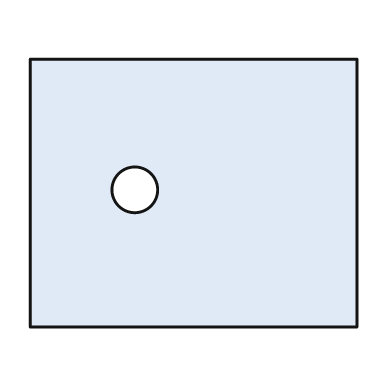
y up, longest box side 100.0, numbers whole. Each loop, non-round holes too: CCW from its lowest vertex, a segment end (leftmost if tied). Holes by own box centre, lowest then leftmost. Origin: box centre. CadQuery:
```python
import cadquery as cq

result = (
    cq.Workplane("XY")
    .moveTo(-50.0, -41.0)
    .lineTo(50.0, -41.0)
    .lineTo(50.0, 41.0)
    .lineTo(-50.0, 41.0)
    .close()
    .moveTo(-18.0, 1.0)
    .circle(7.0)
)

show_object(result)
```